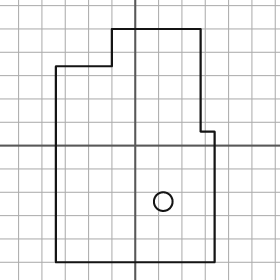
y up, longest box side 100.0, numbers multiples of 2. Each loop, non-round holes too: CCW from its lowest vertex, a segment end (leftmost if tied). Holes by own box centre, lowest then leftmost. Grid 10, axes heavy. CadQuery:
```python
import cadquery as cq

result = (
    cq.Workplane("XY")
    .moveTo(-34.0, -50.0)
    .lineTo(34.0, -50.0)
    .lineTo(34.0, 6.0)
    .lineTo(28.0, 6.0)
    .lineTo(28.0, 50.0)
    .lineTo(-10.0, 50.0)
    .lineTo(-10.0, 34.0)
    .lineTo(-34.0, 34.0)
    .close()
    .moveTo(12.0, -24.0)
    .circle(4.0)
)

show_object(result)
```